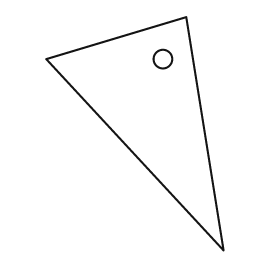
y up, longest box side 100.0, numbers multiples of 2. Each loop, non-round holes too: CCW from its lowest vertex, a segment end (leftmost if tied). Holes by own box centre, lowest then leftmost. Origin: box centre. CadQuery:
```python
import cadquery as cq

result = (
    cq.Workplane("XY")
    .moveTo(38.0, -50.0)
    .lineTo(22.0, 50.0)
    .lineTo(-38.0, 32.0)
    .close()
    .moveTo(12.0, 32.0)
    .circle(4.0)
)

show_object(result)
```